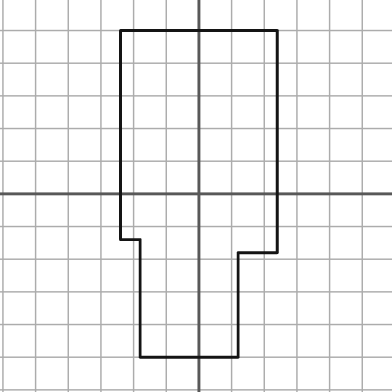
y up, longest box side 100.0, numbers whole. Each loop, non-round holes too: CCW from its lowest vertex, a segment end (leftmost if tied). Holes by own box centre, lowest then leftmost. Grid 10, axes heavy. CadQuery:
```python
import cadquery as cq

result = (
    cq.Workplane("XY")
    .moveTo(-18.0, -50.0)
    .lineTo(12.0, -50.0)
    .lineTo(12.0, -18.0)
    .lineTo(24.0, -18.0)
    .lineTo(24.0, 50.0)
    .lineTo(-24.0, 50.0)
    .lineTo(-24.0, -14.0)
    .lineTo(-18.0, -14.0)
    .close()
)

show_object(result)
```